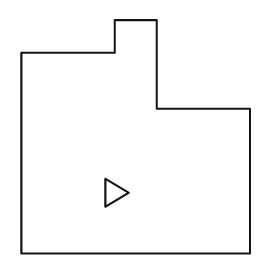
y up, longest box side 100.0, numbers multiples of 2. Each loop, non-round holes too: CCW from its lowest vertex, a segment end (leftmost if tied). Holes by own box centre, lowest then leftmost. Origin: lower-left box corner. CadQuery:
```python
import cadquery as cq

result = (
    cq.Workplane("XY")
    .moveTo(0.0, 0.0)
    .lineTo(98.0, 0.0)
    .lineTo(98.0, 62.0)
    .lineTo(58.0, 62.0)
    .lineTo(58.0, 100.0)
    .lineTo(40.0, 100.0)
    .lineTo(40.0, 86.0)
    .lineTo(0.0, 86.0)
    .close()
    .moveTo(36.0, 20.0)
    .lineTo(46.0, 26.0)
    .lineTo(36.0, 32.0)
    .close()
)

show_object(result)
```